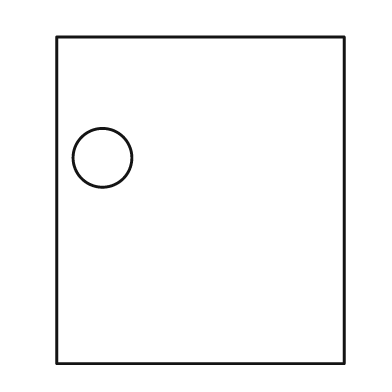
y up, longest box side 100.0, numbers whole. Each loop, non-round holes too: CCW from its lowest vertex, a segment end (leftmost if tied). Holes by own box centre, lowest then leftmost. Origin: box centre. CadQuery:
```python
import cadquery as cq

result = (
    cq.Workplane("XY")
    .moveTo(-44.0, -50.0)
    .lineTo(44.0, -50.0)
    .lineTo(44.0, 50.0)
    .lineTo(-44.0, 50.0)
    .close()
    .moveTo(-30.0, 13.0)
    .circle(9.0)
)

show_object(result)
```